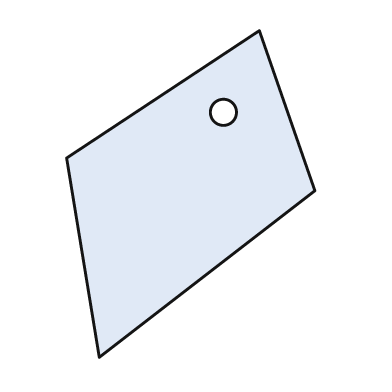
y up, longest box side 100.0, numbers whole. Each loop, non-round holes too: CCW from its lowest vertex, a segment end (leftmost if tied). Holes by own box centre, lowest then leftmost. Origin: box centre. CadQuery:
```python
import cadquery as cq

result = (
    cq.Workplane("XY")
    .moveTo(-28.0, -50.0)
    .lineTo(38.0, 1.0)
    .lineTo(21.0, 50.0)
    .lineTo(-38.0, 11.0)
    .close()
    .moveTo(10.0, 25.0)
    .circle(4.0)
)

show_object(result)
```